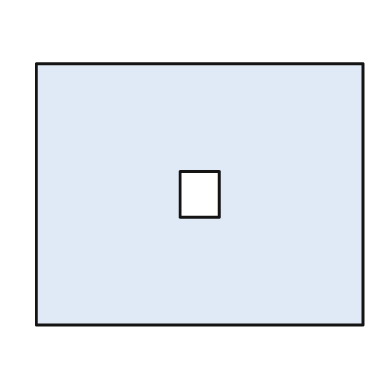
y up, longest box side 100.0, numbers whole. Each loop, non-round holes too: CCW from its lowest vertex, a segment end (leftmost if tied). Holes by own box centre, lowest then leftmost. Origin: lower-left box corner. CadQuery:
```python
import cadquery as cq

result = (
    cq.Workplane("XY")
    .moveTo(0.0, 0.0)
    .lineTo(100.0, 0.0)
    .lineTo(100.0, 80.0)
    .lineTo(0.0, 80.0)
    .close()
    .moveTo(44.0, 33.0)
    .lineTo(56.0, 33.0)
    .lineTo(56.0, 47.0)
    .lineTo(44.0, 47.0)
    .close()
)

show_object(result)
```